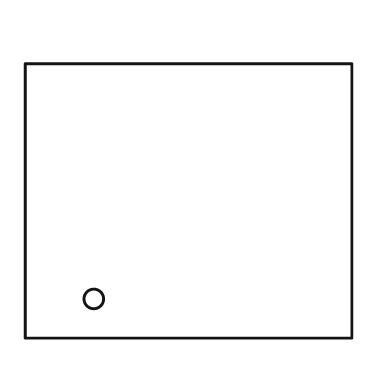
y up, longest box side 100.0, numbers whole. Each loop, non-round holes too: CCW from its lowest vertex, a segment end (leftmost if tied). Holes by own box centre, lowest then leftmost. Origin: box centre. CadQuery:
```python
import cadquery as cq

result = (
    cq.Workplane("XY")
    .moveTo(-50.0, -42.0)
    .lineTo(50.0, -42.0)
    .lineTo(50.0, 42.0)
    .lineTo(-50.0, 42.0)
    .close()
    .moveTo(-29.0, -30.0)
    .circle(3.0)
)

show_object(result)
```